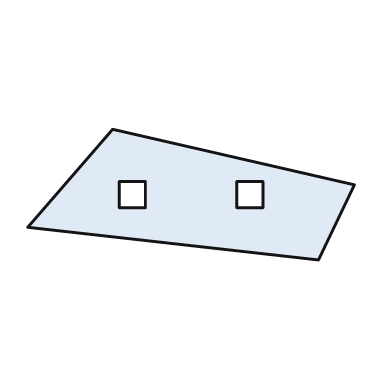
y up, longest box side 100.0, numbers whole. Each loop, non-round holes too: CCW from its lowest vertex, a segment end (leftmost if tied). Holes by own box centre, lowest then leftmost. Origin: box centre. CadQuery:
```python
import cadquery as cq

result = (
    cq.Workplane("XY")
    .moveTo(39.0, -20.0)
    .lineTo(50.0, 3.0)
    .lineTo(-24.0, 20.0)
    .lineTo(-50.0, -10.0)
    .close()
    .moveTo(-22.0, -4.0)
    .lineTo(-14.0, -4.0)
    .lineTo(-14.0, 4.0)
    .lineTo(-22.0, 4.0)
    .close()
    .moveTo(14.0, -4.0)
    .lineTo(22.0, -4.0)
    .lineTo(22.0, 4.0)
    .lineTo(14.0, 4.0)
    .close()
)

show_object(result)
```